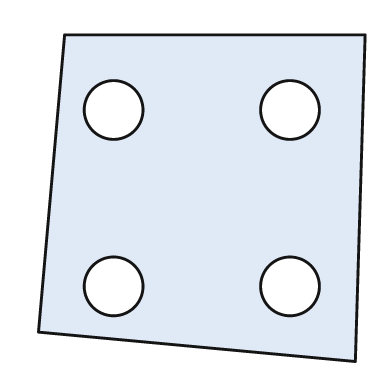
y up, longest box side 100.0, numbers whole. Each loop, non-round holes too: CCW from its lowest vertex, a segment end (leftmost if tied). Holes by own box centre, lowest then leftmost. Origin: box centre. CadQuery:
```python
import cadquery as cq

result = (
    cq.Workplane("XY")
    .moveTo(47.0, -50.0)
    .lineTo(50.0, 50.0)
    .lineTo(-42.0, 50.0)
    .lineTo(-50.0, -41.0)
    .close()
    .moveTo(-27.0, -27.0)
    .circle(9.0)
    .moveTo(27.0, -27.0)
    .circle(9.0)
    .moveTo(-27.0, 27.0)
    .circle(9.0)
    .moveTo(27.0, 27.0)
    .circle(9.0)
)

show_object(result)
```